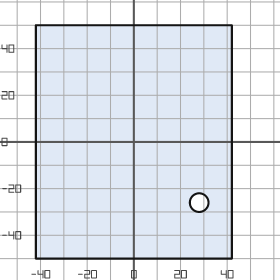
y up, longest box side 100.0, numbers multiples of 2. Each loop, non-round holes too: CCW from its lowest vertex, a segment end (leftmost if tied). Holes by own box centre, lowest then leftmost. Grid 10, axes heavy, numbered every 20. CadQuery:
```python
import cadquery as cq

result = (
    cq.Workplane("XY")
    .moveTo(-42.0, -50.0)
    .lineTo(42.0, -50.0)
    .lineTo(42.0, 50.0)
    .lineTo(-42.0, 50.0)
    .close()
    .moveTo(28.0, -26.0)
    .circle(4.0)
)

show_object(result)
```